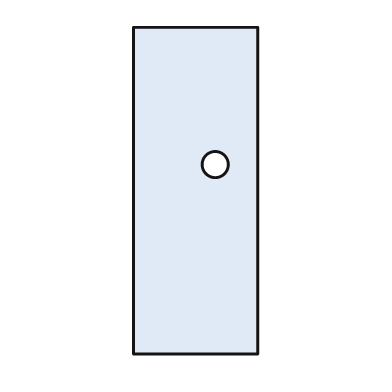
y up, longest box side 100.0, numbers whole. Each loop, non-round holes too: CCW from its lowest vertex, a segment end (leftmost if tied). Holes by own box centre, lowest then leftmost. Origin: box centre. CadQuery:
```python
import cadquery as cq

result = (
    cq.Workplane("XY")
    .moveTo(-19.0, -50.0)
    .lineTo(19.0, -50.0)
    .lineTo(19.0, 50.0)
    .lineTo(-19.0, 50.0)
    .close()
    .moveTo(6.0, 8.0)
    .circle(4.0)
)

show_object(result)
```